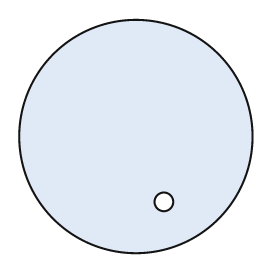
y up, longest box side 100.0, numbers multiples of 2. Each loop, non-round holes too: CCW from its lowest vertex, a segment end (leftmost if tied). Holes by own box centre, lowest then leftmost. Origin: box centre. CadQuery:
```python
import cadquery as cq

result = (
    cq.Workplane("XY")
    .moveTo(0.0, 0.0)
    .circle(50.0)
    .moveTo(12.0, -28.0)
    .circle(4.0)
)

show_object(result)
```